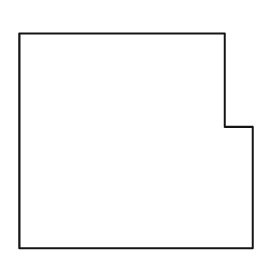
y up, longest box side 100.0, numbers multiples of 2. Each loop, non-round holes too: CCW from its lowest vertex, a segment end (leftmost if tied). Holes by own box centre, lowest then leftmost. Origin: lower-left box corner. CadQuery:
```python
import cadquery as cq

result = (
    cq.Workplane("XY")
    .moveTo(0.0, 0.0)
    .lineTo(100.0, 0.0)
    .lineTo(100.0, 52.0)
    .lineTo(88.0, 52.0)
    .lineTo(88.0, 92.0)
    .lineTo(0.0, 92.0)
    .close()
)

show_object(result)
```